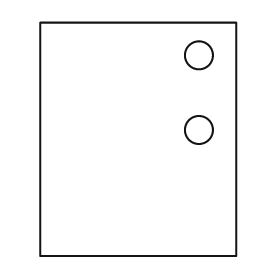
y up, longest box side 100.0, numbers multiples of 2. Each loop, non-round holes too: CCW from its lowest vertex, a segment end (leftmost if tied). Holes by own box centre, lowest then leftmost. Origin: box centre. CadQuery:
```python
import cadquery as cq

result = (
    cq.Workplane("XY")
    .moveTo(-42.0, -50.0)
    .lineTo(42.0, -50.0)
    .lineTo(42.0, 50.0)
    .lineTo(-42.0, 50.0)
    .close()
    .moveTo(26.0, 4.0)
    .circle(6.0)
    .moveTo(26.0, 36.0)
    .circle(6.0)
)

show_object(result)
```